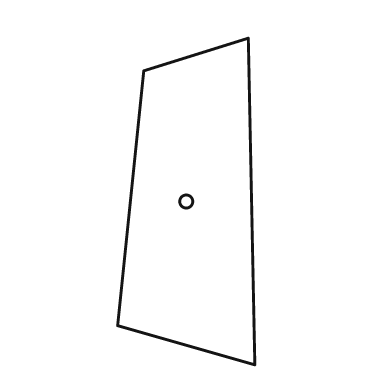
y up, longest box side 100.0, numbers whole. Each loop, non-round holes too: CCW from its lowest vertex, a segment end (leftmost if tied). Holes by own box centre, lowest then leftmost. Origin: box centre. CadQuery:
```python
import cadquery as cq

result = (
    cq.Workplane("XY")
    .moveTo(21.0, -50.0)
    .lineTo(19.0, 50.0)
    .lineTo(-13.0, 40.0)
    .lineTo(-21.0, -38.0)
    .close()
    .moveTo(0.0, 0.0)
    .circle(2.0)
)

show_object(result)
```